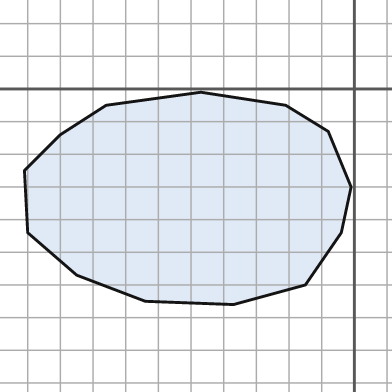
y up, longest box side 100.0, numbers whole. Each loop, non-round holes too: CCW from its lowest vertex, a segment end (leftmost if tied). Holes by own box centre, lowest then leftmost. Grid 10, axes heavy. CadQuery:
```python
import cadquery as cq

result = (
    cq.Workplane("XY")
    .moveTo(-37.0, -66.0)
    .lineTo(-15.0, -60.0)
    .lineTo(-4.0, -44.0)
    .lineTo(-1.0, -30.0)
    .lineTo(-8.0, -13.0)
    .lineTo(-21.0, -5.0)
    .lineTo(-47.0, -1.0)
    .lineTo(-76.0, -5.0)
    .lineTo(-90.0, -14.0)
    .lineTo(-101.0, -25.0)
    .lineTo(-100.0, -44.0)
    .lineTo(-85.0, -57.0)
    .lineTo(-64.0, -65.0)
    .close()
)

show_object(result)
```